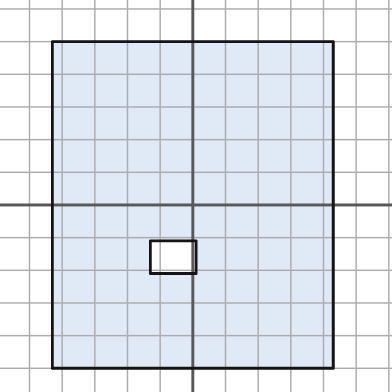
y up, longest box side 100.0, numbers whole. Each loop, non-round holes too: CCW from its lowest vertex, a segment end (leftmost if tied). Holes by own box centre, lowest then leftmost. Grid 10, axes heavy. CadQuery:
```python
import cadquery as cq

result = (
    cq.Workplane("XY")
    .moveTo(-43.0, -50.0)
    .lineTo(43.0, -50.0)
    .lineTo(43.0, 50.0)
    .lineTo(-43.0, 50.0)
    .close()
    .moveTo(-13.0, -21.0)
    .lineTo(1.0, -21.0)
    .lineTo(1.0, -11.0)
    .lineTo(-13.0, -11.0)
    .close()
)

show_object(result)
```